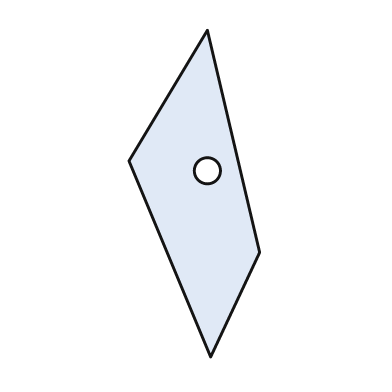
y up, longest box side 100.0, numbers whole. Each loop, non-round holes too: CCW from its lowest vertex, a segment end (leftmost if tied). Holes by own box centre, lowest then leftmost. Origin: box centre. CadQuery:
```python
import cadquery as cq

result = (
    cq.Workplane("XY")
    .moveTo(5.0, -50.0)
    .lineTo(20.0, -18.0)
    .lineTo(4.0, 50.0)
    .lineTo(-20.0, 10.0)
    .close()
    .moveTo(4.0, 7.0)
    .circle(4.0)
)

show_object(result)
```